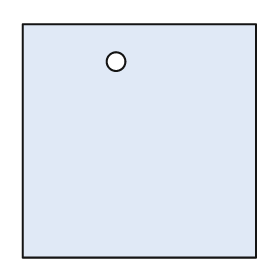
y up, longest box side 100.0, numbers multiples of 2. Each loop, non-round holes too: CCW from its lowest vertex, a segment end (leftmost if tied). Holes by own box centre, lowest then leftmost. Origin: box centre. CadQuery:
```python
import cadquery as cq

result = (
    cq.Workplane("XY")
    .moveTo(-50.0, -50.0)
    .lineTo(50.0, -50.0)
    .lineTo(50.0, 50.0)
    .lineTo(-50.0, 50.0)
    .close()
    .moveTo(-10.0, 34.0)
    .circle(4.0)
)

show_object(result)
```